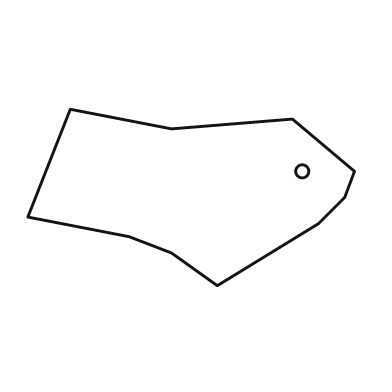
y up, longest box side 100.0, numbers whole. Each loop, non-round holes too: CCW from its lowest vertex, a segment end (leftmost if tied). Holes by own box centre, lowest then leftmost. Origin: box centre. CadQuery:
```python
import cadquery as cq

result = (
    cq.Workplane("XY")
    .moveTo(8.0, -27.0)
    .lineTo(39.0, -8.0)
    .lineTo(47.0, 0.0)
    .lineTo(50.0, 8.0)
    .lineTo(31.0, 24.0)
    .lineTo(-6.0, 21.0)
    .lineTo(-37.0, 27.0)
    .lineTo(-50.0, -6.0)
    .lineTo(-19.0, -12.0)
    .lineTo(-6.0, -17.0)
    .close()
    .moveTo(34.0, 8.0)
    .circle(2.0)
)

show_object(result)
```